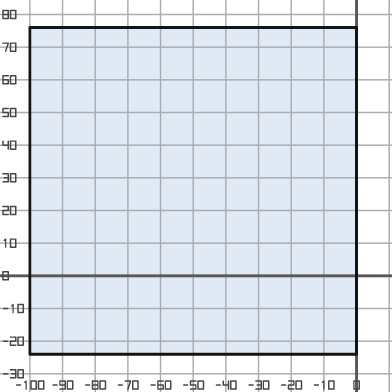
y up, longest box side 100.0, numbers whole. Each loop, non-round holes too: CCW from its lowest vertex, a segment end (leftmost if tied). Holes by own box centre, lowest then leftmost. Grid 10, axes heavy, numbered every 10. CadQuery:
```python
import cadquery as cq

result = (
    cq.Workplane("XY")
    .moveTo(-100.0, -24.0)
    .lineTo(0.0, -24.0)
    .lineTo(0.0, 76.0)
    .lineTo(-100.0, 76.0)
    .close()
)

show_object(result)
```